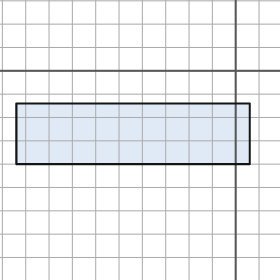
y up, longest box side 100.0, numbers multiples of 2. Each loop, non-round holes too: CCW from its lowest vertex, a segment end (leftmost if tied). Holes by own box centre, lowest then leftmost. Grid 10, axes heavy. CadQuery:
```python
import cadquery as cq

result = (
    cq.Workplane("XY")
    .moveTo(-94.0, -40.0)
    .lineTo(6.0, -40.0)
    .lineTo(6.0, -14.0)
    .lineTo(-94.0, -14.0)
    .close()
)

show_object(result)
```